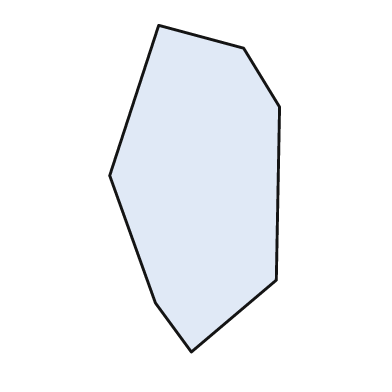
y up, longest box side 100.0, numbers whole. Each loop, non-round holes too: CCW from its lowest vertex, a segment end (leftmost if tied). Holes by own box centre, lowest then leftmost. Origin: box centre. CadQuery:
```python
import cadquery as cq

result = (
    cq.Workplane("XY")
    .moveTo(-1.0, -50.0)
    .lineTo(25.0, -28.0)
    .lineTo(26.0, 25.0)
    .lineTo(15.0, 43.0)
    .lineTo(-11.0, 50.0)
    .lineTo(-26.0, 4.0)
    .lineTo(-12.0, -35.0)
    .close()
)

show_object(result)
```